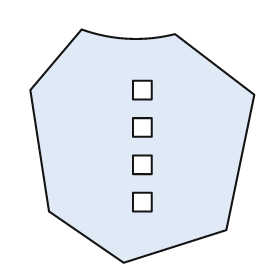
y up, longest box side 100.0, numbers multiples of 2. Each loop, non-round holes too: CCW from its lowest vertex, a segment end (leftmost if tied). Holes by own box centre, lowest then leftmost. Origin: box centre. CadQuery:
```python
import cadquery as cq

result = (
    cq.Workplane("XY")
    .moveTo(-8.0, -50.0)
    .lineTo(36.0, -36.0)
    .lineTo(48.0, 22.0)
    .lineTo(14.0, 48.0)
    .threePointArc((-6.0, 46.0), (-26.0, 50.0))
    .lineTo(-48.0, 24.0)
    .lineTo(-40.0, -28.0)
    .close()
    .moveTo(-4.0, -28.0)
    .lineTo(4.0, -28.0)
    .lineTo(4.0, -20.0)
    .lineTo(-4.0, -20.0)
    .close()
    .moveTo(-4.0, -12.0)
    .lineTo(4.0, -12.0)
    .lineTo(4.0, -4.0)
    .lineTo(-4.0, -4.0)
    .close()
    .moveTo(-4.0, 4.0)
    .lineTo(4.0, 4.0)
    .lineTo(4.0, 12.0)
    .lineTo(-4.0, 12.0)
    .close()
    .moveTo(-4.0, 20.0)
    .lineTo(4.0, 20.0)
    .lineTo(4.0, 28.0)
    .lineTo(-4.0, 28.0)
    .close()
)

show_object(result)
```